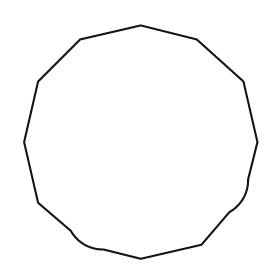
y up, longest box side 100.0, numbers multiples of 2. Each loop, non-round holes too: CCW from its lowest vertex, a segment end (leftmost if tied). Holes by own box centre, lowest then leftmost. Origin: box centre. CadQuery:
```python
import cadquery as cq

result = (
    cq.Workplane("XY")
    .moveTo(0.0, -50.0)
    .lineTo(26.0, -44.0)
    .lineTo(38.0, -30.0)
    .threePointArc((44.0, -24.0), (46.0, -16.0))
    .lineTo(50.0, 0.0)
    .lineTo(44.0, 26.0)
    .lineTo(24.0, 44.0)
    .lineTo(0.0, 50.0)
    .lineTo(-26.0, 44.0)
    .lineTo(-44.0, 26.0)
    .lineTo(-50.0, 0.0)
    .lineTo(-44.0, -26.0)
    .lineTo(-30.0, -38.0)
    .threePointArc((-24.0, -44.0), (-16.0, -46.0))
    .close()
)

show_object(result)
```